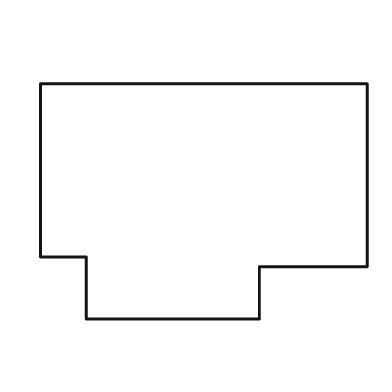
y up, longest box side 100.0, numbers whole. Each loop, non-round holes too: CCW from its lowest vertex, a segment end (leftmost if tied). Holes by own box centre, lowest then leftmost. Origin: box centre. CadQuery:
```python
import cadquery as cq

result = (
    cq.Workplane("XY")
    .moveTo(-36.0, -36.0)
    .lineTo(17.0, -36.0)
    .lineTo(17.0, -20.0)
    .lineTo(50.0, -20.0)
    .lineTo(50.0, 36.0)
    .lineTo(-50.0, 36.0)
    .lineTo(-50.0, -17.0)
    .lineTo(-36.0, -17.0)
    .close()
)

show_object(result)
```